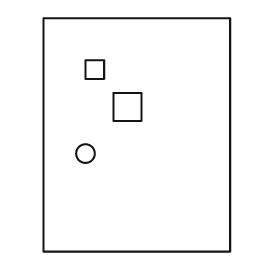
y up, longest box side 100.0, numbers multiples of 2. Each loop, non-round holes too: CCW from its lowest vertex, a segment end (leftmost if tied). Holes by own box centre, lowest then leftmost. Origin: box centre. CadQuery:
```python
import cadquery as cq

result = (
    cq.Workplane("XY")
    .moveTo(-40.0, -50.0)
    .lineTo(40.0, -50.0)
    .lineTo(40.0, 50.0)
    .lineTo(-40.0, 50.0)
    .close()
    .moveTo(-22.0, -8.0)
    .circle(4.0)
    .moveTo(-10.0, 6.0)
    .lineTo(2.0, 6.0)
    .lineTo(2.0, 18.0)
    .lineTo(-10.0, 18.0)
    .close()
    .moveTo(-22.0, 24.0)
    .lineTo(-14.0, 24.0)
    .lineTo(-14.0, 32.0)
    .lineTo(-22.0, 32.0)
    .close()
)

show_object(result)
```